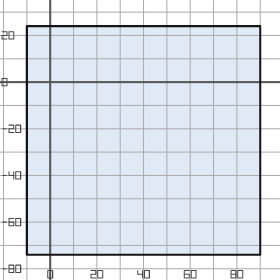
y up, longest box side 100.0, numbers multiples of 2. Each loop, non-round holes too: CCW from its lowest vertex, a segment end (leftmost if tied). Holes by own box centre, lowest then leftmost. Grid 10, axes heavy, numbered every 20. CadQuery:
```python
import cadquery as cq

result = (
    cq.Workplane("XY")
    .moveTo(-10.0, -74.0)
    .lineTo(90.0, -74.0)
    .lineTo(90.0, 24.0)
    .lineTo(-10.0, 24.0)
    .close()
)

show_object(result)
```